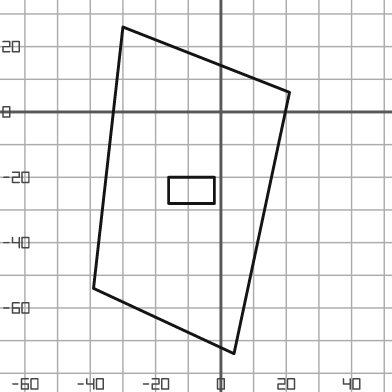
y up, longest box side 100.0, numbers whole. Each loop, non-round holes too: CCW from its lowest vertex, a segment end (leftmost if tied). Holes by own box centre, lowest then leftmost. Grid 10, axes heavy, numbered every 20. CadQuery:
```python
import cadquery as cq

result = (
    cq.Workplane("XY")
    .moveTo(4.0, -74.0)
    .lineTo(21.0, 6.0)
    .lineTo(-30.0, 26.0)
    .lineTo(-39.0, -54.0)
    .close()
    .moveTo(-16.0, -28.0)
    .lineTo(-2.0, -28.0)
    .lineTo(-2.0, -20.0)
    .lineTo(-16.0, -20.0)
    .close()
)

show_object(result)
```